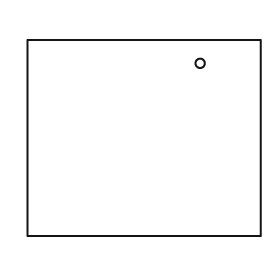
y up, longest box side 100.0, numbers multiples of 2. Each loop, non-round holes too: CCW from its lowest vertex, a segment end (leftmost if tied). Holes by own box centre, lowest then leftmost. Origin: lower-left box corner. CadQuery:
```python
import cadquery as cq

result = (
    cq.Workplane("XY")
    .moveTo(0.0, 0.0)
    .lineTo(100.0, 0.0)
    .lineTo(100.0, 84.0)
    .lineTo(0.0, 84.0)
    .close()
    .moveTo(74.0, 74.0)
    .circle(2.0)
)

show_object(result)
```